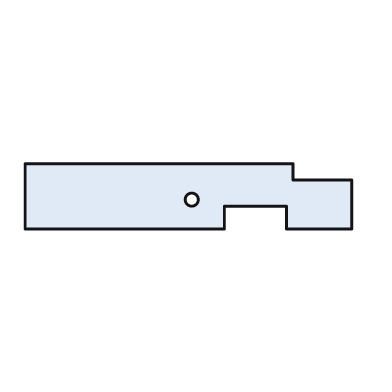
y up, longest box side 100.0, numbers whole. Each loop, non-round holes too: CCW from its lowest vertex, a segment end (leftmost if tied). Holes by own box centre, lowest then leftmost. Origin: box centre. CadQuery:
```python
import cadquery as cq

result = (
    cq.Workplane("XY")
    .moveTo(-50.0, -10.0)
    .lineTo(11.0, -10.0)
    .lineTo(11.0, -3.0)
    .lineTo(30.0, -3.0)
    .lineTo(30.0, -10.0)
    .lineTo(50.0, -10.0)
    .lineTo(50.0, 5.0)
    .lineTo(32.0, 5.0)
    .lineTo(32.0, 10.0)
    .lineTo(-50.0, 10.0)
    .close()
    .moveTo(1.0, -1.0)
    .circle(2.0)
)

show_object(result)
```